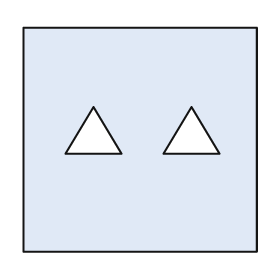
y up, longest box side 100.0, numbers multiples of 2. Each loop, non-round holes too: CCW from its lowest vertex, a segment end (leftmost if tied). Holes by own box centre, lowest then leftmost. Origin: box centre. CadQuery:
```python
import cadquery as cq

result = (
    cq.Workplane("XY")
    .moveTo(-50.0, -48.0)
    .lineTo(50.0, -48.0)
    .lineTo(50.0, 48.0)
    .lineTo(-50.0, 48.0)
    .close()
    .moveTo(-32.0, -6.0)
    .lineTo(-8.0, -6.0)
    .lineTo(-20.0, 14.0)
    .close()
    .moveTo(10.0, -6.0)
    .lineTo(34.0, -6.0)
    .lineTo(22.0, 14.0)
    .close()
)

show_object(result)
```